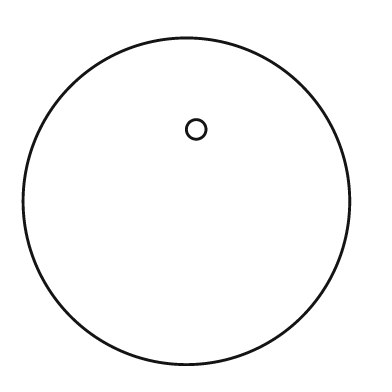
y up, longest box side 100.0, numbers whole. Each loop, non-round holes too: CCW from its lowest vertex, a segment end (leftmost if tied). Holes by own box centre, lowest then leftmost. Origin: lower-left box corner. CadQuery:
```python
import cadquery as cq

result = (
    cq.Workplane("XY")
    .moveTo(50.0, 50.0)
    .circle(50.0)
    .moveTo(53.0, 72.0)
    .circle(3.0)
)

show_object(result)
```